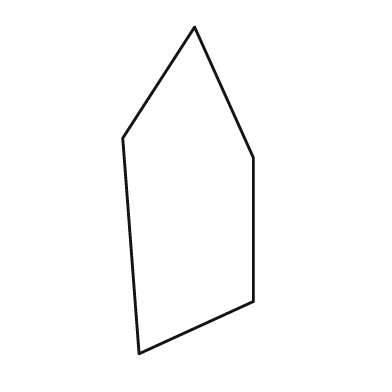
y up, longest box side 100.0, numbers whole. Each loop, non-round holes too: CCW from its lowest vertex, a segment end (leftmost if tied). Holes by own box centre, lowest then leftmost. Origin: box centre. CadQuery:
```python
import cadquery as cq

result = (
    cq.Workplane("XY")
    .moveTo(-15.0, -50.0)
    .lineTo(20.0, -34.0)
    .lineTo(20.0, 10.0)
    .lineTo(2.0, 50.0)
    .lineTo(-20.0, 16.0)
    .close()
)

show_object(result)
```